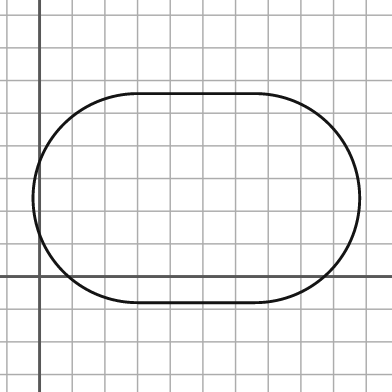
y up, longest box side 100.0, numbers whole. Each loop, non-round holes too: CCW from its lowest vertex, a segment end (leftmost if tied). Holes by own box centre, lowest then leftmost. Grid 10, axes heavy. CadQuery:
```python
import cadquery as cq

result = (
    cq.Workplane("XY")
    .moveTo(30.0, -8.0)
    .lineTo(66.0, -8.0)
    .threePointArc((98.0, 24.0), (66.0, 56.0))
    .lineTo(30.0, 56.0)
    .threePointArc((-2.0, 24.0), (30.0, -8.0))
    .close()
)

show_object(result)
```